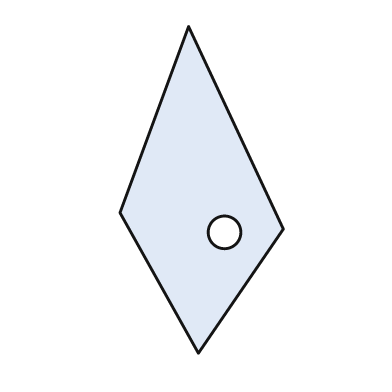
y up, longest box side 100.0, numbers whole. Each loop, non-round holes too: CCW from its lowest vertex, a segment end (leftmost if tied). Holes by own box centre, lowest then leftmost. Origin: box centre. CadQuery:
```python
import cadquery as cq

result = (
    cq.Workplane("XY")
    .moveTo(-1.0, -50.0)
    .lineTo(25.0, -12.0)
    .lineTo(-4.0, 50.0)
    .lineTo(-25.0, -7.0)
    .close()
    .moveTo(7.0, -13.0)
    .circle(5.0)
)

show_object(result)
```